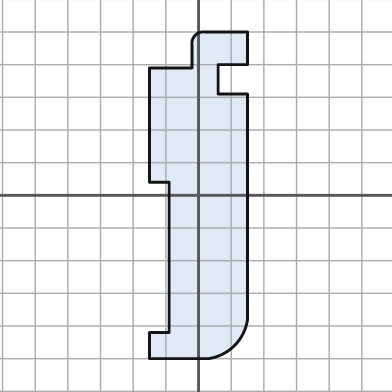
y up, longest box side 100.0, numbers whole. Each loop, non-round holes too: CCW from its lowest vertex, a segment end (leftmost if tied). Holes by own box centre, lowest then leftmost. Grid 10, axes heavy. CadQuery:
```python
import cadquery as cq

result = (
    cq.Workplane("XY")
    .moveTo(-15.0, -50.0)
    .lineTo(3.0, -50.0)
    .threePointArc((11.0, -46.0), (15.0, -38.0))
    .lineTo(15.0, 31.0)
    .lineTo(6.0, 31.0)
    .lineTo(6.0, 40.0)
    .lineTo(15.0, 40.0)
    .lineTo(15.0, 50.0)
    .lineTo(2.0, 50.0)
    .threePointArc((-1.0, 49.0), (-2.0, 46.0))
    .lineTo(-2.0, 39.0)
    .lineTo(-15.0, 39.0)
    .lineTo(-15.0, 4.0)
    .lineTo(-9.0, 4.0)
    .lineTo(-9.0, -42.0)
    .lineTo(-15.0, -42.0)
    .close()
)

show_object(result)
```